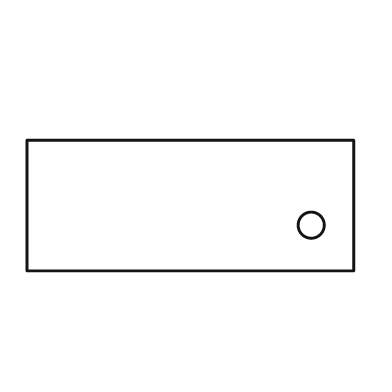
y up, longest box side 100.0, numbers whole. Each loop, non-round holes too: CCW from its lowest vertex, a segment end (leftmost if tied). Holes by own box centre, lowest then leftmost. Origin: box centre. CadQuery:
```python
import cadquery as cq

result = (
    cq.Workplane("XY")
    .moveTo(-50.0, -20.0)
    .lineTo(50.0, -20.0)
    .lineTo(50.0, 20.0)
    .lineTo(-50.0, 20.0)
    .close()
    .moveTo(37.0, -6.0)
    .circle(4.0)
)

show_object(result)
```